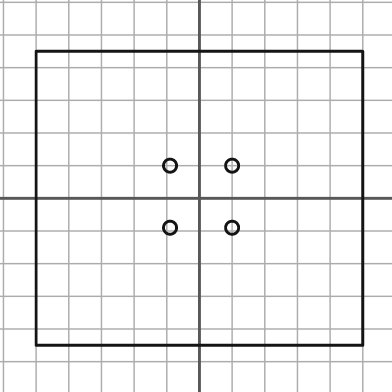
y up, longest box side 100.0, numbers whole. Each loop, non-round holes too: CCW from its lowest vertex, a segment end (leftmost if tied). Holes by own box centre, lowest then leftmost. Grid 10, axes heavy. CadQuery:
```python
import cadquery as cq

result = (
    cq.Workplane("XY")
    .moveTo(-50.0, -45.0)
    .lineTo(50.0, -45.0)
    .lineTo(50.0, 45.0)
    .lineTo(-50.0, 45.0)
    .close()
    .moveTo(-9.0, -9.0)
    .circle(2.0)
    .moveTo(10.0, -9.0)
    .circle(2.0)
    .moveTo(-9.0, 10.0)
    .circle(2.0)
    .moveTo(10.0, 10.0)
    .circle(2.0)
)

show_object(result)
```